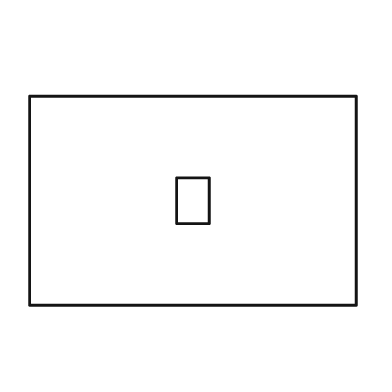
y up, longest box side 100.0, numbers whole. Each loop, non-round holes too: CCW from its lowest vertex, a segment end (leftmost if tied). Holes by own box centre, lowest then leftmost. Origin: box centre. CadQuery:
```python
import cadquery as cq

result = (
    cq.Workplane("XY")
    .moveTo(-50.0, -32.0)
    .lineTo(50.0, -32.0)
    .lineTo(50.0, 32.0)
    .lineTo(-50.0, 32.0)
    .close()
    .moveTo(-5.0, -7.0)
    .lineTo(5.0, -7.0)
    .lineTo(5.0, 7.0)
    .lineTo(-5.0, 7.0)
    .close()
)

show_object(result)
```